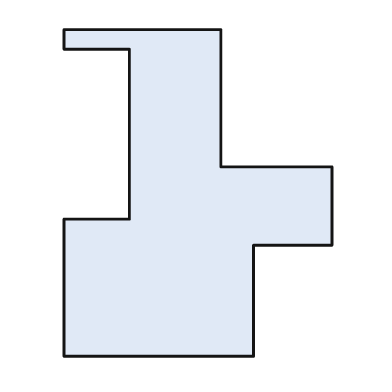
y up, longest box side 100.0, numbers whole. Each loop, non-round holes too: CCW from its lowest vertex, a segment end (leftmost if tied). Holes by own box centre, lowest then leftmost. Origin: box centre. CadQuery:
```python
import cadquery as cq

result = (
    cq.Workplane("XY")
    .moveTo(-41.0, -50.0)
    .lineTo(17.0, -50.0)
    .lineTo(17.0, -16.0)
    .lineTo(41.0, -16.0)
    .lineTo(41.0, 8.0)
    .lineTo(7.0, 8.0)
    .lineTo(7.0, 50.0)
    .lineTo(-41.0, 50.0)
    .lineTo(-41.0, 44.0)
    .lineTo(-21.0, 44.0)
    .lineTo(-21.0, -8.0)
    .lineTo(-41.0, -8.0)
    .close()
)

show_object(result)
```